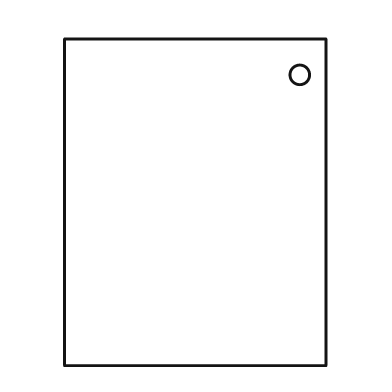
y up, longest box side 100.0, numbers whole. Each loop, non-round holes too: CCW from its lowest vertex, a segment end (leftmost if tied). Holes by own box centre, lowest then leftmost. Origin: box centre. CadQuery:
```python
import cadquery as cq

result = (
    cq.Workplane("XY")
    .moveTo(-40.0, -50.0)
    .lineTo(40.0, -50.0)
    .lineTo(40.0, 50.0)
    .lineTo(-40.0, 50.0)
    .close()
    .moveTo(32.0, 39.0)
    .circle(3.0)
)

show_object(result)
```